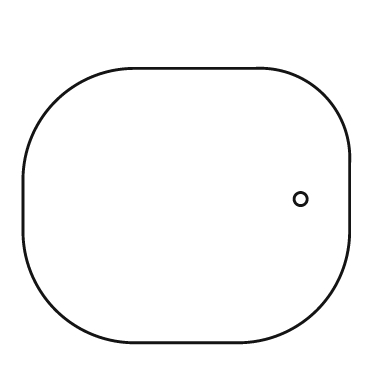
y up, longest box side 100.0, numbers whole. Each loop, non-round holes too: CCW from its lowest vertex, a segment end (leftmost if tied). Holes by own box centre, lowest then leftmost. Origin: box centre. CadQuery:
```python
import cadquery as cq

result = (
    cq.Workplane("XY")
    .moveTo(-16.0, -42.0)
    .lineTo(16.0, -42.0)
    .threePointArc((40.0, -32.0), (50.0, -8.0))
    .lineTo(50.0, 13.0)
    .threePointArc((42.0, 34.0), (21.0, 42.0))
    .lineTo(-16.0, 42.0)
    .threePointArc((-40.0, 32.0), (-50.0, 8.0))
    .lineTo(-50.0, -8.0)
    .threePointArc((-40.0, -32.0), (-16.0, -42.0))
    .close()
    .moveTo(35.0, 2.0)
    .circle(2.0)
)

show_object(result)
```